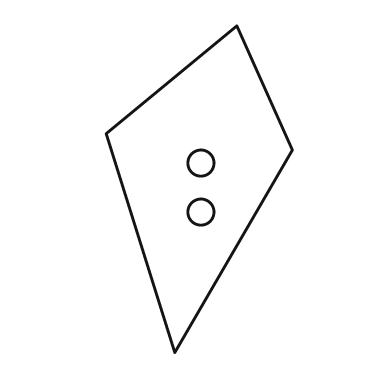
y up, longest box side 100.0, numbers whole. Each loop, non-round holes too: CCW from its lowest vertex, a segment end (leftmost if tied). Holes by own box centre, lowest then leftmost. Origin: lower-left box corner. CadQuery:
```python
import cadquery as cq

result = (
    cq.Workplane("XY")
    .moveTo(21.0, 0.0)
    .lineTo(57.0, 62.0)
    .lineTo(40.0, 100.0)
    .lineTo(0.0, 67.0)
    .close()
    .moveTo(29.0, 43.0)
    .circle(4.0)
    .moveTo(29.0, 58.0)
    .circle(4.0)
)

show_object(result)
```